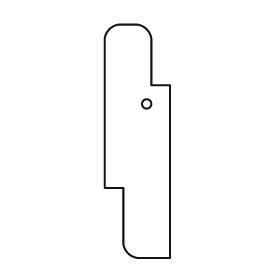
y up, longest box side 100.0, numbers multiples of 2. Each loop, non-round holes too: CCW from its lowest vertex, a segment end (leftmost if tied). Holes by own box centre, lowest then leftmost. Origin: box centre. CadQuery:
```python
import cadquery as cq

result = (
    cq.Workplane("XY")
    .moveTo(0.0, -50.0)
    .lineTo(14.0, -50.0)
    .lineTo(14.0, 24.0)
    .lineTo(6.0, 24.0)
    .lineTo(6.0, 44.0)
    .threePointArc((4.0, 48.0), (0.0, 50.0))
    .lineTo(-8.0, 50.0)
    .threePointArc((-12.0, 48.0), (-14.0, 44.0))
    .lineTo(-14.0, -20.0)
    .lineTo(-6.0, -20.0)
    .lineTo(-6.0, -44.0)
    .threePointArc((-4.0, -48.0), (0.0, -50.0))
    .close()
    .moveTo(4.0, 16.0)
    .circle(2.0)
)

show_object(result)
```